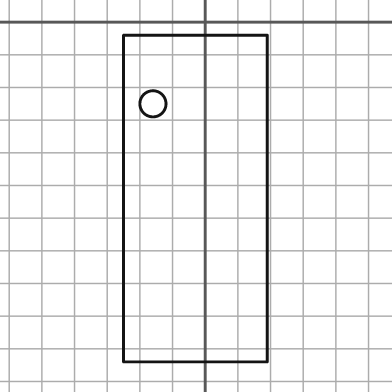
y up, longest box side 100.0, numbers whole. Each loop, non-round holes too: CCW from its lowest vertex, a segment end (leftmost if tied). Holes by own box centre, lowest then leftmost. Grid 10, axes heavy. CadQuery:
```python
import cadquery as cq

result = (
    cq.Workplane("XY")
    .moveTo(-25.0, -104.0)
    .lineTo(19.0, -104.0)
    .lineTo(19.0, -4.0)
    .lineTo(-25.0, -4.0)
    .close()
    .moveTo(-16.0, -25.0)
    .circle(4.0)
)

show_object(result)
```